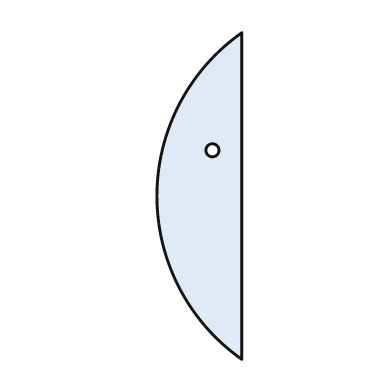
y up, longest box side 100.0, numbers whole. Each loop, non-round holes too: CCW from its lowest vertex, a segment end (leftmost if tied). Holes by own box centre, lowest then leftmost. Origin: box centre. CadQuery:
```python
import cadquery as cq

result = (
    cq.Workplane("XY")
    .moveTo(13.0, -50.0)
    .lineTo(13.0, 50.0)
    .threePointArc((-13.0, 0.0), (13.0, -50.0))
    .close()
    .moveTo(4.0, 14.0)
    .circle(2.0)
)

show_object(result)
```